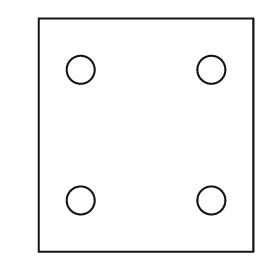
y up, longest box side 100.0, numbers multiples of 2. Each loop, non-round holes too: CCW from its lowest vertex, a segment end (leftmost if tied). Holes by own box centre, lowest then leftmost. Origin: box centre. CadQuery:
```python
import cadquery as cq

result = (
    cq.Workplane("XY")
    .moveTo(-46.0, -50.0)
    .lineTo(46.0, -50.0)
    .lineTo(46.0, 50.0)
    .lineTo(-46.0, 50.0)
    .close()
    .moveTo(-28.0, -28.0)
    .circle(6.0)
    .moveTo(28.0, -28.0)
    .circle(6.0)
    .moveTo(-28.0, 28.0)
    .circle(6.0)
    .moveTo(28.0, 28.0)
    .circle(6.0)
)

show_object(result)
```